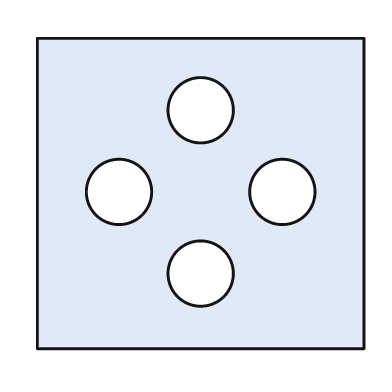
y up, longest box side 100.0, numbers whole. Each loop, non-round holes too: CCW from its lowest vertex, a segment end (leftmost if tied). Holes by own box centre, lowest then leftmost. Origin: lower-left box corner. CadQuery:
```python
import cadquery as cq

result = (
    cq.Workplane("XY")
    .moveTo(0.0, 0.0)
    .lineTo(100.0, 0.0)
    .lineTo(100.0, 95.0)
    .lineTo(0.0, 95.0)
    .close()
    .moveTo(50.0, 23.0)
    .circle(10.0)
    .moveTo(25.0, 48.0)
    .circle(10.0)
    .moveTo(75.0, 48.0)
    .circle(10.0)
    .moveTo(50.0, 73.0)
    .circle(10.0)
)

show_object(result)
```